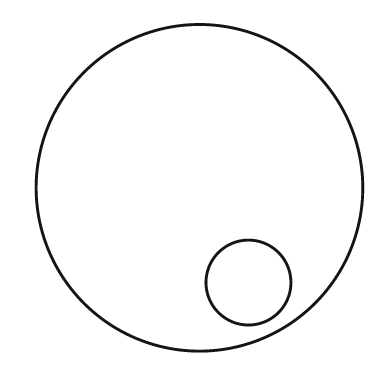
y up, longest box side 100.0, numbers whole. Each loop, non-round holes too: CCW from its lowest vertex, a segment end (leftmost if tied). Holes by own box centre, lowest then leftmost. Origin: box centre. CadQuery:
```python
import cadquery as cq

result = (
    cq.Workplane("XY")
    .moveTo(0.0, 0.0)
    .circle(50.0)
    .moveTo(15.0, -29.0)
    .circle(13.0)
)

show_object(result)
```